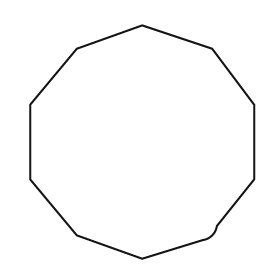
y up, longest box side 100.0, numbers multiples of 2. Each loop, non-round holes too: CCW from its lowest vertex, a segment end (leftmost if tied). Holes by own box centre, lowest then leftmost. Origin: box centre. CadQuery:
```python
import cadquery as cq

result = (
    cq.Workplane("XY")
    .moveTo(0.0, -50.0)
    .lineTo(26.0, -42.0)
    .threePointArc((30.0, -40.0), (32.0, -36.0))
    .lineTo(48.0, -16.0)
    .lineTo(48.0, 16.0)
    .lineTo(30.0, 40.0)
    .lineTo(0.0, 50.0)
    .lineTo(-28.0, 40.0)
    .lineTo(-48.0, 16.0)
    .lineTo(-48.0, -16.0)
    .lineTo(-28.0, -40.0)
    .close()
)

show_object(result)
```